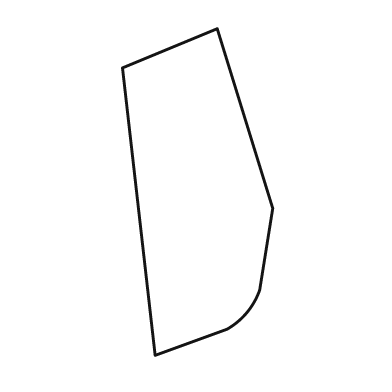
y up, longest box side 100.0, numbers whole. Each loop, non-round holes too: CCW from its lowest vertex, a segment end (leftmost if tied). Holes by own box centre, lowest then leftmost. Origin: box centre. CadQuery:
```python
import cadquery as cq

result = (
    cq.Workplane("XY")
    .moveTo(-13.0, -50.0)
    .lineTo(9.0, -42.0)
    .threePointArc((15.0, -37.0), (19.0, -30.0))
    .lineTo(23.0, -5.0)
    .lineTo(6.0, 50.0)
    .lineTo(-23.0, 38.0)
    .close()
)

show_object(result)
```